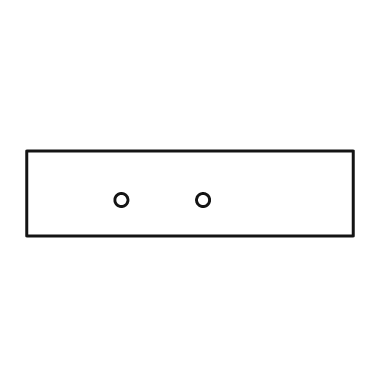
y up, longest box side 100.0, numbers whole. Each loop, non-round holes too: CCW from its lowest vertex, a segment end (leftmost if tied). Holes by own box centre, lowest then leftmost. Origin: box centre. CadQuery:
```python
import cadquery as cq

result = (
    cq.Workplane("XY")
    .moveTo(-50.0, -13.0)
    .lineTo(50.0, -13.0)
    .lineTo(50.0, 13.0)
    .lineTo(-50.0, 13.0)
    .close()
    .moveTo(-21.0, -2.0)
    .circle(2.0)
    .moveTo(4.0, -2.0)
    .circle(2.0)
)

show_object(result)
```